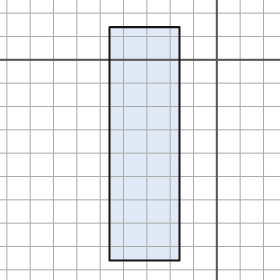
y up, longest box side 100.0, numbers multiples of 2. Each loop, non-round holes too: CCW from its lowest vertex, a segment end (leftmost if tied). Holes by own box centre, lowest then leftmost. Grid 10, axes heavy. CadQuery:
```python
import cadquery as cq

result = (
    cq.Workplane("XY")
    .moveTo(-46.0, -86.0)
    .lineTo(-16.0, -86.0)
    .lineTo(-16.0, 14.0)
    .lineTo(-46.0, 14.0)
    .close()
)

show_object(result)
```